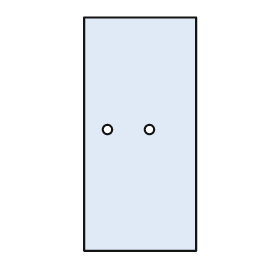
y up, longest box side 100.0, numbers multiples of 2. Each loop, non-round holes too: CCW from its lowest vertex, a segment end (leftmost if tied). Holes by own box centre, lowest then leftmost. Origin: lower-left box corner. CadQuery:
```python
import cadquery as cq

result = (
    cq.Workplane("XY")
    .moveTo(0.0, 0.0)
    .lineTo(48.0, 0.0)
    .lineTo(48.0, 100.0)
    .lineTo(0.0, 100.0)
    .close()
    .moveTo(10.0, 52.0)
    .circle(2.0)
    .moveTo(28.0, 52.0)
    .circle(2.0)
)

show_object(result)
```